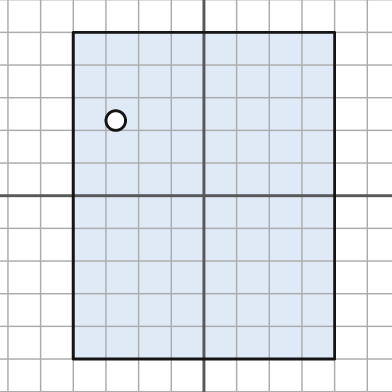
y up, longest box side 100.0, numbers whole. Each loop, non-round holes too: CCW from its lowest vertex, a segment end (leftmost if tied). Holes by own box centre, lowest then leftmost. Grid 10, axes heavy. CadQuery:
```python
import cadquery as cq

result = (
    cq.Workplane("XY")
    .moveTo(-40.0, -50.0)
    .lineTo(40.0, -50.0)
    .lineTo(40.0, 50.0)
    .lineTo(-40.0, 50.0)
    .close()
    .moveTo(-27.0, 23.0)
    .circle(3.0)
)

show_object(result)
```